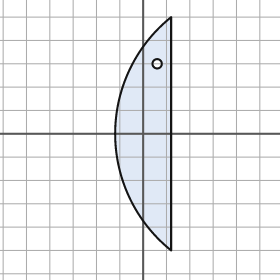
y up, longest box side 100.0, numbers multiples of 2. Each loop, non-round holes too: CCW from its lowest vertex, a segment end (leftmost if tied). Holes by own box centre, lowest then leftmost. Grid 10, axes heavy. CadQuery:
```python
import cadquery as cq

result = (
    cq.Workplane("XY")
    .moveTo(12.0, -50.0)
    .lineTo(12.0, 50.0)
    .threePointArc((-12.0, 0.0), (12.0, -50.0))
    .close()
    .moveTo(6.0, 30.0)
    .circle(2.0)
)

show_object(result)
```